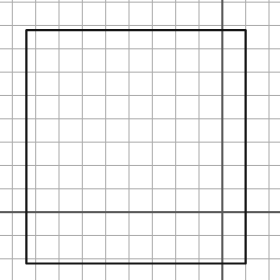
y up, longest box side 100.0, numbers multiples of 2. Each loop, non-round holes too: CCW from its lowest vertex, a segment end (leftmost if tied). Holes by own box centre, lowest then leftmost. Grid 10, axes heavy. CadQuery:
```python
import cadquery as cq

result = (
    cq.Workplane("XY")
    .moveTo(-84.0, -22.0)
    .lineTo(10.0, -22.0)
    .lineTo(10.0, 78.0)
    .lineTo(-84.0, 78.0)
    .close()
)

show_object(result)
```